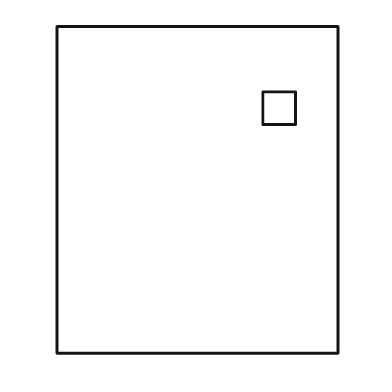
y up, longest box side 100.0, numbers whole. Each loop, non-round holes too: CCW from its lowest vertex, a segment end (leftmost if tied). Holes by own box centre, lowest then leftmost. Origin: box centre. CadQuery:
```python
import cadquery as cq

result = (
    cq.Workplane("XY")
    .moveTo(-43.0, -50.0)
    .lineTo(43.0, -50.0)
    .lineTo(43.0, 50.0)
    .lineTo(-43.0, 50.0)
    .close()
    .moveTo(20.0, 20.0)
    .lineTo(30.0, 20.0)
    .lineTo(30.0, 30.0)
    .lineTo(20.0, 30.0)
    .close()
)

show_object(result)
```